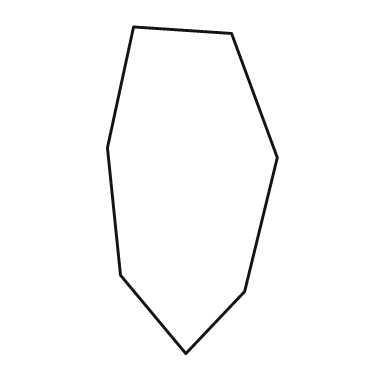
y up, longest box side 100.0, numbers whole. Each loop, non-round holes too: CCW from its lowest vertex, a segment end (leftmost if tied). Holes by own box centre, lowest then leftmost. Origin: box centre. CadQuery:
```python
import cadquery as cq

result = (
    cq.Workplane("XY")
    .moveTo(-2.0, -50.0)
    .lineTo(16.0, -31.0)
    .lineTo(26.0, 10.0)
    .lineTo(12.0, 48.0)
    .lineTo(-18.0, 50.0)
    .lineTo(-26.0, 13.0)
    .lineTo(-22.0, -26.0)
    .close()
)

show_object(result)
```